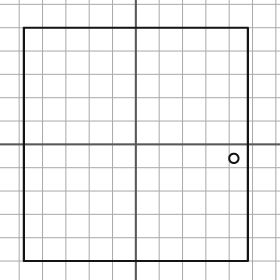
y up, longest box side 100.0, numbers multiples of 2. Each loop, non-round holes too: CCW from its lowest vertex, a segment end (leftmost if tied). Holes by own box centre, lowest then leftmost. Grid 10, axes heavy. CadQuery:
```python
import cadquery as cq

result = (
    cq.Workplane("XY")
    .moveTo(-48.0, -50.0)
    .lineTo(48.0, -50.0)
    .lineTo(48.0, 50.0)
    .lineTo(-48.0, 50.0)
    .close()
    .moveTo(42.0, -6.0)
    .circle(2.0)
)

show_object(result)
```